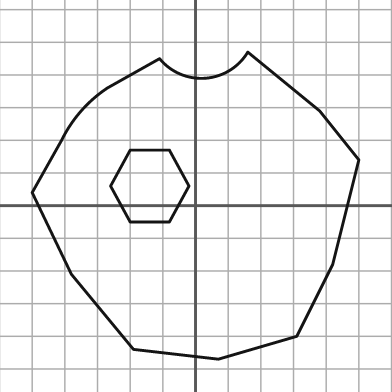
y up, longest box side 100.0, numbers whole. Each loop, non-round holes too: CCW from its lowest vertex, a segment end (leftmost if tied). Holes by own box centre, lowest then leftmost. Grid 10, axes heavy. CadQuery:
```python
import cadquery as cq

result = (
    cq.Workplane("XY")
    .moveTo(7.0, -47.0)
    .lineTo(31.0, -40.0)
    .lineTo(42.0, -18.0)
    .lineTo(50.0, 14.0)
    .lineTo(38.0, 29.0)
    .lineTo(16.0, 47.0)
    .threePointArc((3.0, 39.0), (-11.0, 45.0))
    .lineTo(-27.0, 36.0)
    .threePointArc((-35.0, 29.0), (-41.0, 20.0))
    .lineTo(-50.0, 4.0)
    .lineTo(-38.0, -21.0)
    .lineTo(-19.0, -44.0)
    .close()
    .moveTo(-20.0, -5.0)
    .lineTo(-8.0, -5.0)
    .lineTo(-2.0, 6.0)
    .lineTo(-8.0, 17.0)
    .lineTo(-20.0, 17.0)
    .lineTo(-26.0, 6.0)
    .close()
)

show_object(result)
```